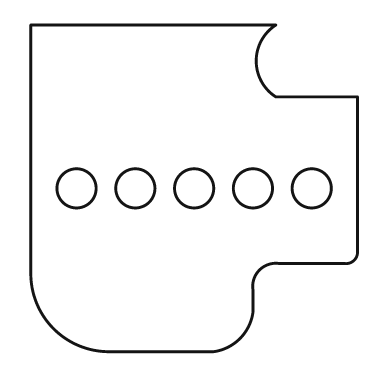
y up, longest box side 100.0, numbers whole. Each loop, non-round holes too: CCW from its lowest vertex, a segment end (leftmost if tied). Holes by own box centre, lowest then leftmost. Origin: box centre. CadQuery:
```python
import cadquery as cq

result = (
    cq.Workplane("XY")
    .moveTo(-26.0, -50.0)
    .lineTo(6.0, -50.0)
    .threePointArc((14.0, -46.0), (18.0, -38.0))
    .lineTo(18.0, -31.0)
    .threePointArc((20.0, -25.0), (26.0, -23.0))
    .lineTo(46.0, -23.0)
    .threePointArc((49.0, -22.0), (50.0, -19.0))
    .lineTo(50.0, 28.0)
    .lineTo(25.0, 28.0)
    .threePointArc((19.0, 39.0), (25.0, 50.0))
    .lineTo(-50.0, 50.0)
    .lineTo(-50.0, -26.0)
    .threePointArc((-43.0, -43.0), (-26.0, -50.0))
    .close()
    .moveTo(-36.0, 0.0)
    .circle(6.0)
    .moveTo(-18.0, 0.0)
    .circle(6.0)
    .moveTo(0.0, 0.0)
    .circle(6.0)
    .moveTo(18.0, 0.0)
    .circle(6.0)
    .moveTo(36.0, 0.0)
    .circle(6.0)
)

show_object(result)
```